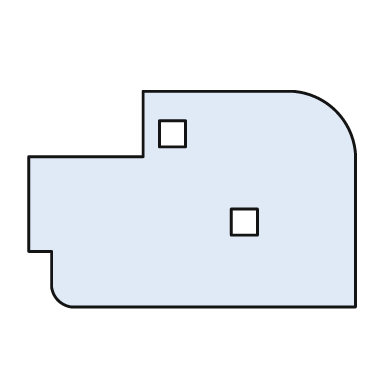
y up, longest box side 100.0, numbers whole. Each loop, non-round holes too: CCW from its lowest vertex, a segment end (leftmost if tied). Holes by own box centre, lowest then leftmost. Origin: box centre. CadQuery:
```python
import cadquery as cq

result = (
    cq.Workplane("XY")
    .moveTo(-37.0, -33.0)
    .lineTo(50.0, -33.0)
    .lineTo(50.0, 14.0)
    .threePointArc((44.0, 27.0), (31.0, 33.0))
    .lineTo(-15.0, 33.0)
    .lineTo(-15.0, 13.0)
    .lineTo(-50.0, 13.0)
    .lineTo(-50.0, -16.0)
    .lineTo(-43.0, -16.0)
    .lineTo(-43.0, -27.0)
    .threePointArc((-41.0, -31.0), (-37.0, -33.0))
    .close()
    .moveTo(12.0, -11.0)
    .lineTo(20.0, -11.0)
    .lineTo(20.0, -3.0)
    .lineTo(12.0, -3.0)
    .close()
    .moveTo(-10.0, 16.0)
    .lineTo(-2.0, 16.0)
    .lineTo(-2.0, 24.0)
    .lineTo(-10.0, 24.0)
    .close()
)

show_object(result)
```